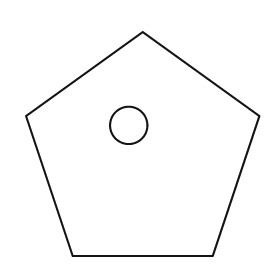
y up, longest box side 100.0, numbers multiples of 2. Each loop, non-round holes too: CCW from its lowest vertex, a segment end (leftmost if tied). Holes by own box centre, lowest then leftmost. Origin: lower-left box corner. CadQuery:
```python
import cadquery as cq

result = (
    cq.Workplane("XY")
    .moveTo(20.0, 0.0)
    .lineTo(80.0, 0.0)
    .lineTo(100.0, 60.0)
    .lineTo(50.0, 96.0)
    .lineTo(0.0, 60.0)
    .close()
    .moveTo(44.0, 56.0)
    .circle(8.0)
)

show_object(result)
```